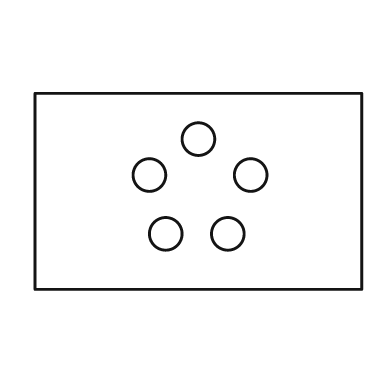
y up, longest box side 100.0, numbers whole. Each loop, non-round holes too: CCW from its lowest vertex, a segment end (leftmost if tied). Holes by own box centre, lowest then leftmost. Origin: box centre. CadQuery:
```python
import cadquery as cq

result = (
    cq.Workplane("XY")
    .moveTo(-50.0, -30.0)
    .lineTo(50.0, -30.0)
    .lineTo(50.0, 30.0)
    .lineTo(-50.0, 30.0)
    .close()
    .moveTo(-10.0, -13.0)
    .circle(5.0)
    .moveTo(9.0, -13.0)
    .circle(5.0)
    .moveTo(-15.0, 5.0)
    .circle(5.0)
    .moveTo(16.0, 5.0)
    .circle(5.0)
    .moveTo(0.0, 16.0)
    .circle(5.0)
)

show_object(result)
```